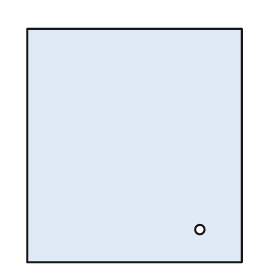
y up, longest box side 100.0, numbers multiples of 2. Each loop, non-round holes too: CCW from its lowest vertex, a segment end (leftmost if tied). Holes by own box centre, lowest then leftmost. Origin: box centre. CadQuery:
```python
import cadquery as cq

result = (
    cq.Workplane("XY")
    .moveTo(-46.0, -50.0)
    .lineTo(46.0, -50.0)
    .lineTo(46.0, 50.0)
    .lineTo(-46.0, 50.0)
    .close()
    .moveTo(28.0, -36.0)
    .circle(2.0)
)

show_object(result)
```